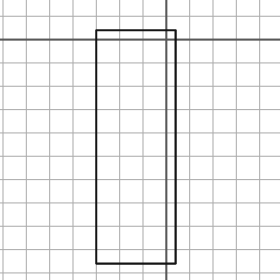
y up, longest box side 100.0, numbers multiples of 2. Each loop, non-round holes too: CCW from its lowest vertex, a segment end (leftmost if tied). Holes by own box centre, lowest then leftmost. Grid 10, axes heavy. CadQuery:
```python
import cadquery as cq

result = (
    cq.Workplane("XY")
    .moveTo(-30.0, -96.0)
    .lineTo(4.0, -96.0)
    .lineTo(4.0, 4.0)
    .lineTo(-30.0, 4.0)
    .close()
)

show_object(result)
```